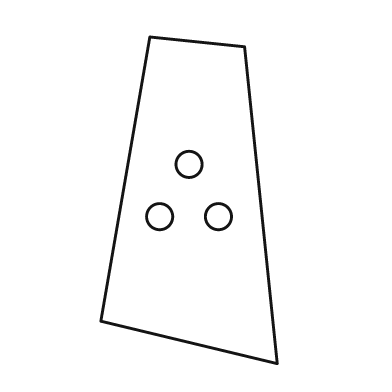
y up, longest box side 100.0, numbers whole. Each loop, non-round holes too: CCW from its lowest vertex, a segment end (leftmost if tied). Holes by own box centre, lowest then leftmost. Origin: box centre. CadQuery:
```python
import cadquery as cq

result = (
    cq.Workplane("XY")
    .moveTo(27.0, -50.0)
    .lineTo(17.0, 47.0)
    .lineTo(-12.0, 50.0)
    .lineTo(-27.0, -37.0)
    .close()
    .moveTo(-9.0, -5.0)
    .circle(4.0)
    .moveTo(9.0, -5.0)
    .circle(4.0)
    .moveTo(0.0, 11.0)
    .circle(4.0)
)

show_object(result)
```